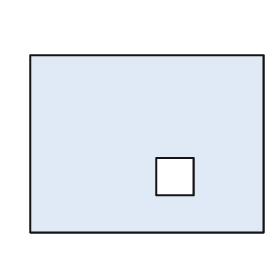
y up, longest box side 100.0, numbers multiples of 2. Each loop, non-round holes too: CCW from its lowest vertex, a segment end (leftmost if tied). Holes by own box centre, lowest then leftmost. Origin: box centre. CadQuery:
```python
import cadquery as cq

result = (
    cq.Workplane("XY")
    .moveTo(-50.0, -38.0)
    .lineTo(50.0, -38.0)
    .lineTo(50.0, 38.0)
    .lineTo(-50.0, 38.0)
    .close()
    .moveTo(4.0, -22.0)
    .lineTo(20.0, -22.0)
    .lineTo(20.0, -6.0)
    .lineTo(4.0, -6.0)
    .close()
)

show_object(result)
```